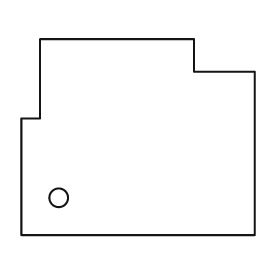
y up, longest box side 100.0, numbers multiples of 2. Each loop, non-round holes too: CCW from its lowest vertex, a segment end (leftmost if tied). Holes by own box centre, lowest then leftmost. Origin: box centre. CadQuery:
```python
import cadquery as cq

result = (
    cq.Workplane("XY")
    .moveTo(-50.0, -42.0)
    .lineTo(50.0, -42.0)
    .lineTo(50.0, 28.0)
    .lineTo(24.0, 28.0)
    .lineTo(24.0, 42.0)
    .lineTo(-42.0, 42.0)
    .lineTo(-42.0, 8.0)
    .lineTo(-50.0, 8.0)
    .close()
    .moveTo(-34.0, -26.0)
    .circle(4.0)
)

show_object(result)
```